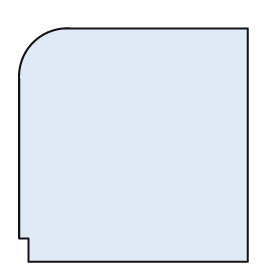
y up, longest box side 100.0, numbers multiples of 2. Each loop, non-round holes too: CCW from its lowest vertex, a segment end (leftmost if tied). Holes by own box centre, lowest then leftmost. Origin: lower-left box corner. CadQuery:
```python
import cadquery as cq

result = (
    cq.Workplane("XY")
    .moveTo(4.0, 0.0)
    .lineTo(98.0, 0.0)
    .lineTo(98.0, 100.0)
    .lineTo(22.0, 100.0)
    .threePointArc((6.0, 94.0), (0.0, 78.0))
    .lineTo(0.0, 10.0)
    .lineTo(4.0, 10.0)
    .close()
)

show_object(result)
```